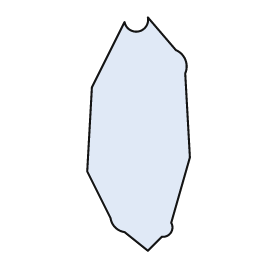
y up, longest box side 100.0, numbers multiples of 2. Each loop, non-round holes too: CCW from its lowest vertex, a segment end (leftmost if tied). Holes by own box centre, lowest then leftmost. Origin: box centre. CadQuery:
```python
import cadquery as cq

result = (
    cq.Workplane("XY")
    .moveTo(4.0, -50.0)
    .lineTo(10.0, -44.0)
    .threePointArc((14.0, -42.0), (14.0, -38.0))
    .lineTo(22.0, -10.0)
    .lineTo(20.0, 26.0)
    .threePointArc((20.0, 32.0), (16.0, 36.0))
    .lineTo(4.0, 50.0)
    .threePointArc((0.0, 44.0), (-6.0, 48.0))
    .lineTo(-20.0, 20.0)
    .lineTo(-22.0, -16.0)
    .lineTo(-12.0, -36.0)
    .threePointArc((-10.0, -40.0), (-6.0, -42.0))
    .close()
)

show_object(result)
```